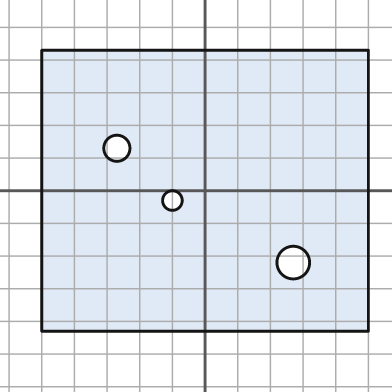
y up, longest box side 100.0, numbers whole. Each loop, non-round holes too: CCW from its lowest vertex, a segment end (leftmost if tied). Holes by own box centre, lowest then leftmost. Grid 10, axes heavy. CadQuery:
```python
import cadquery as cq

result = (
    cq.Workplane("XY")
    .moveTo(-50.0, -43.0)
    .lineTo(50.0, -43.0)
    .lineTo(50.0, 43.0)
    .lineTo(-50.0, 43.0)
    .close()
    .moveTo(27.0, -22.0)
    .circle(5.0)
    .moveTo(-10.0, -3.0)
    .circle(3.0)
    .moveTo(-27.0, 13.0)
    .circle(4.0)
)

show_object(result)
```